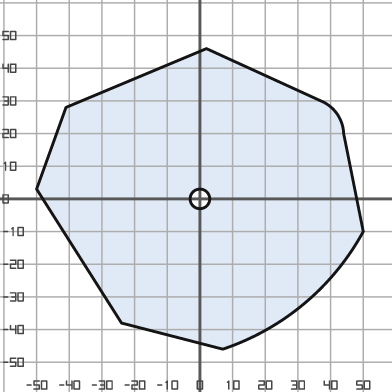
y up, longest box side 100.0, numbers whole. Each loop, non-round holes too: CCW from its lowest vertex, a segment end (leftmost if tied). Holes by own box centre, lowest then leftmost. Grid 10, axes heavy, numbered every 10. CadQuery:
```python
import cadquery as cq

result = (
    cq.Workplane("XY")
    .moveTo(7.0, -46.0)
    .threePointArc((32.0, -32.0), (50.0, -10.0))
    .lineTo(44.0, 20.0)
    .threePointArc((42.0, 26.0), (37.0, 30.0))
    .lineTo(2.0, 46.0)
    .lineTo(-41.0, 28.0)
    .lineTo(-50.0, 3.0)
    .lineTo(-24.0, -38.0)
    .close()
    .moveTo(0.0, 0.0)
    .circle(3.0)
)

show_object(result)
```